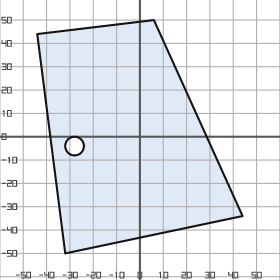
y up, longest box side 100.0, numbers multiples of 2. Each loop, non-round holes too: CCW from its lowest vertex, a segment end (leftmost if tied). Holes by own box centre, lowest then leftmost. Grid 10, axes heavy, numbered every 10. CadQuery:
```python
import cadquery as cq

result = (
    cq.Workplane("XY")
    .moveTo(-32.0, -50.0)
    .lineTo(44.0, -34.0)
    .lineTo(6.0, 50.0)
    .lineTo(-44.0, 44.0)
    .close()
    .moveTo(-28.0, -4.0)
    .circle(4.0)
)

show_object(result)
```